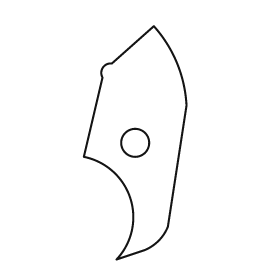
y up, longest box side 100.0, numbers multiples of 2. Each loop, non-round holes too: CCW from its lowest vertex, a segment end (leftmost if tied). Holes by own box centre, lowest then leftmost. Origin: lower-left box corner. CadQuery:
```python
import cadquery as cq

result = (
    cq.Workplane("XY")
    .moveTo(14.0, 0.0)
    .lineTo(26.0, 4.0)
    .threePointArc((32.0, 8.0), (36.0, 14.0))
    .lineTo(44.0, 66.0)
    .threePointArc((40.0, 84.0), (30.0, 100.0))
    .lineTo(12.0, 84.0)
    .threePointArc((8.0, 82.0), (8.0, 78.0))
    .lineTo(0.0, 44.0)
    .threePointArc((20.0, 26.0), (14.0, 0.0))
    .close()
    .moveTo(22.0, 50.0)
    .circle(6.0)
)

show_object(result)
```